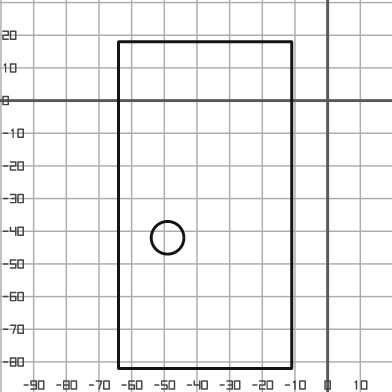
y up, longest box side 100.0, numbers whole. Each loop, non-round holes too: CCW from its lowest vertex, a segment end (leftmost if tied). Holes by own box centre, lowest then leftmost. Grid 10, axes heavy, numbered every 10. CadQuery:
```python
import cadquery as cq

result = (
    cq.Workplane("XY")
    .moveTo(-64.0, -82.0)
    .lineTo(-11.0, -82.0)
    .lineTo(-11.0, 18.0)
    .lineTo(-64.0, 18.0)
    .close()
    .moveTo(-49.0, -42.0)
    .circle(5.0)
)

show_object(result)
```